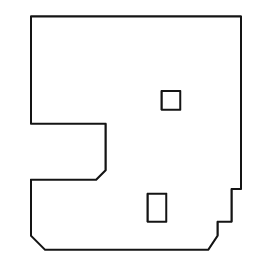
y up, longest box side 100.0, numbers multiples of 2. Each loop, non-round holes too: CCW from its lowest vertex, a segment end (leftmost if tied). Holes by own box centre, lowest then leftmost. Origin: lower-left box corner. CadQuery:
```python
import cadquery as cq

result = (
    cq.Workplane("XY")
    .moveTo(6.0, 0.0)
    .lineTo(76.0, 0.0)
    .lineTo(80.0, 6.0)
    .lineTo(80.0, 12.0)
    .lineTo(86.0, 12.0)
    .lineTo(86.0, 26.0)
    .lineTo(90.0, 26.0)
    .lineTo(90.0, 100.0)
    .lineTo(0.0, 100.0)
    .lineTo(0.0, 54.0)
    .lineTo(32.0, 54.0)
    .lineTo(32.0, 34.0)
    .lineTo(28.0, 30.0)
    .lineTo(0.0, 30.0)
    .lineTo(0.0, 6.0)
    .close()
    .moveTo(50.0, 12.0)
    .lineTo(58.0, 12.0)
    .lineTo(58.0, 24.0)
    .lineTo(50.0, 24.0)
    .close()
    .moveTo(56.0, 60.0)
    .lineTo(64.0, 60.0)
    .lineTo(64.0, 68.0)
    .lineTo(56.0, 68.0)
    .close()
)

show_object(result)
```